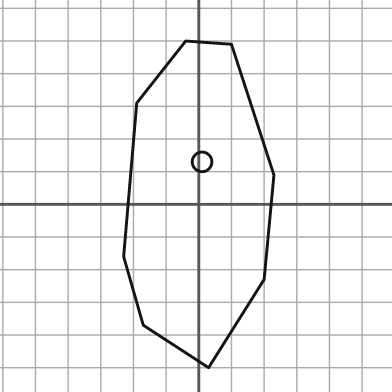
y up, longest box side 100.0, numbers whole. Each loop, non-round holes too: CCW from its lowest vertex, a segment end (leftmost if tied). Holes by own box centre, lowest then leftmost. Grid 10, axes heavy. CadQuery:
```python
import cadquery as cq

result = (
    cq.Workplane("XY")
    .moveTo(3.0, -50.0)
    .lineTo(20.0, -23.0)
    .lineTo(23.0, 9.0)
    .lineTo(10.0, 49.0)
    .lineTo(-4.0, 50.0)
    .lineTo(-19.0, 31.0)
    .lineTo(-23.0, -16.0)
    .lineTo(-17.0, -37.0)
    .close()
    .moveTo(1.0, 13.0)
    .circle(3.0)
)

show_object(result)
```